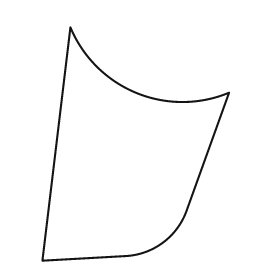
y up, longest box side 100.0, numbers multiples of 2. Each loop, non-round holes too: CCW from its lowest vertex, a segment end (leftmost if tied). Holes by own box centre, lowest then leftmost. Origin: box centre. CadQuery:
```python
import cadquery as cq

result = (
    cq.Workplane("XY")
    .moveTo(-40.0, -50.0)
    .lineTo(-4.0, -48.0)
    .threePointArc((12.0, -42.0), (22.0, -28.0))
    .lineTo(40.0, 22.0)
    .threePointArc((0.0, 22.0), (-28.0, 50.0))
    .close()
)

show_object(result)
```